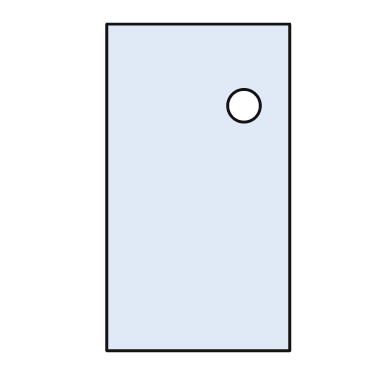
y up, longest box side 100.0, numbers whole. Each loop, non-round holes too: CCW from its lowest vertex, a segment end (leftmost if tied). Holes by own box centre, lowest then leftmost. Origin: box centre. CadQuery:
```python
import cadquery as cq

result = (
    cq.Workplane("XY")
    .moveTo(-28.0, -50.0)
    .lineTo(28.0, -50.0)
    .lineTo(28.0, 50.0)
    .lineTo(-28.0, 50.0)
    .close()
    .moveTo(14.0, 25.0)
    .circle(5.0)
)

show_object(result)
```